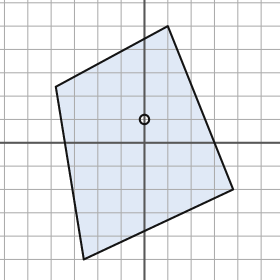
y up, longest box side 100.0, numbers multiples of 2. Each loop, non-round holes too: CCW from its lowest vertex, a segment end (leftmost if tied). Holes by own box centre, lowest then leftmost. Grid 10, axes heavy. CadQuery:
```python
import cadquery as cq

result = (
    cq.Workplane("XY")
    .moveTo(-26.0, -50.0)
    .lineTo(38.0, -20.0)
    .lineTo(10.0, 50.0)
    .lineTo(-38.0, 24.0)
    .close()
    .moveTo(0.0, 10.0)
    .circle(2.0)
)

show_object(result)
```